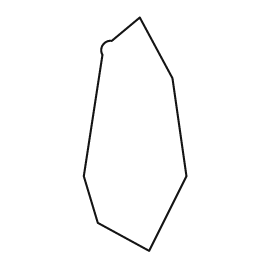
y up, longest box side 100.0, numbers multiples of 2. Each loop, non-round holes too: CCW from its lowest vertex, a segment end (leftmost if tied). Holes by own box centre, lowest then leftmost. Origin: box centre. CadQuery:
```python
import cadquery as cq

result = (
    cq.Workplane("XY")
    .moveTo(6.0, -50.0)
    .lineTo(22.0, -18.0)
    .lineTo(16.0, 24.0)
    .lineTo(2.0, 50.0)
    .lineTo(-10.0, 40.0)
    .threePointArc((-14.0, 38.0), (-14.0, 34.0))
    .lineTo(-22.0, -18.0)
    .lineTo(-16.0, -38.0)
    .close()
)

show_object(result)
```